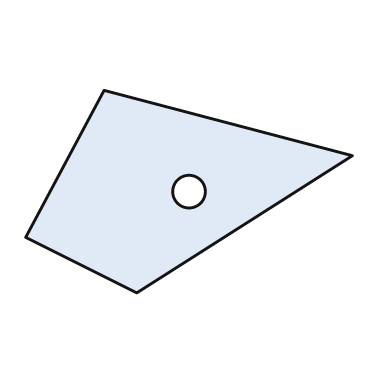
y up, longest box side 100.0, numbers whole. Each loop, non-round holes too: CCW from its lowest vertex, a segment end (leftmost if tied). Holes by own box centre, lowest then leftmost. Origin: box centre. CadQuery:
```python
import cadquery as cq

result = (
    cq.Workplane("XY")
    .moveTo(-16.0, -31.0)
    .lineTo(50.0, 11.0)
    .lineTo(-26.0, 31.0)
    .lineTo(-50.0, -14.0)
    .close()
    .moveTo(0.0, 0.0)
    .circle(5.0)
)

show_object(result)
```